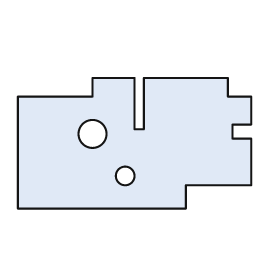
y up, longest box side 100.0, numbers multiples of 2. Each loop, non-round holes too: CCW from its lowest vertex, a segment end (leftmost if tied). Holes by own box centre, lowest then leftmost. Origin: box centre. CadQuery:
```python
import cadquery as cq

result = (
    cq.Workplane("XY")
    .moveTo(-50.0, -28.0)
    .lineTo(22.0, -28.0)
    .lineTo(22.0, -18.0)
    .lineTo(50.0, -18.0)
    .lineTo(50.0, 2.0)
    .lineTo(42.0, 2.0)
    .lineTo(42.0, 8.0)
    .lineTo(50.0, 8.0)
    .lineTo(50.0, 20.0)
    .lineTo(40.0, 20.0)
    .lineTo(40.0, 28.0)
    .lineTo(4.0, 28.0)
    .lineTo(4.0, 6.0)
    .lineTo(0.0, 6.0)
    .lineTo(0.0, 28.0)
    .lineTo(-18.0, 28.0)
    .lineTo(-18.0, 20.0)
    .lineTo(-50.0, 20.0)
    .close()
    .moveTo(-4.0, -14.0)
    .circle(4.0)
    .moveTo(-18.0, 4.0)
    .circle(6.0)
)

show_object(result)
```